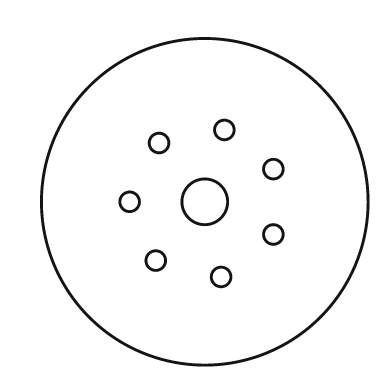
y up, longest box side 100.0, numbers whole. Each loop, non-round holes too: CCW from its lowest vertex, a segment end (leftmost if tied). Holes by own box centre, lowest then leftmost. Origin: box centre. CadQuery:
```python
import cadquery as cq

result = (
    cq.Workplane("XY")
    .moveTo(0.0, 0.0)
    .circle(50.0)
    .moveTo(5.0, -23.0)
    .circle(3.0)
    .moveTo(-15.0, -18.0)
    .circle(3.0)
    .moveTo(21.0, -10.0)
    .circle(3.0)
    .moveTo(-23.0, 0.0)
    .circle(3.0)
    .moveTo(0.0, 0.0)
    .circle(7.0)
    .moveTo(21.0, 10.0)
    .circle(3.0)
    .moveTo(-14.0, 18.0)
    .circle(3.0)
    .moveTo(6.0, 22.0)
    .circle(3.0)
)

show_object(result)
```